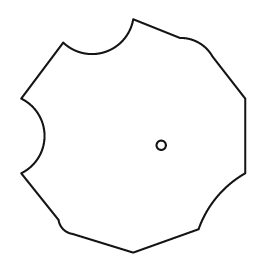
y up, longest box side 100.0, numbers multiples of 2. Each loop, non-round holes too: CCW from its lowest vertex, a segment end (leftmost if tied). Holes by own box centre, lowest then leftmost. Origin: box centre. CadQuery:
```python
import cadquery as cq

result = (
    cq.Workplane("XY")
    .moveTo(0.0, -50.0)
    .lineTo(28.0, -40.0)
    .threePointArc((36.0, -26.0), (48.0, -16.0))
    .lineTo(48.0, 16.0)
    .lineTo(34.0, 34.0)
    .threePointArc((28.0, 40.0), (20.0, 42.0))
    .lineTo(0.0, 50.0)
    .threePointArc((-12.0, 36.0), (-30.0, 40.0))
    .lineTo(-48.0, 16.0)
    .threePointArc((-38.0, 0.0), (-48.0, -16.0))
    .lineTo(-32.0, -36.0)
    .threePointArc((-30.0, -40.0), (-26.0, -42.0))
    .close()
    .moveTo(12.0, -4.0)
    .circle(2.0)
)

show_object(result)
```